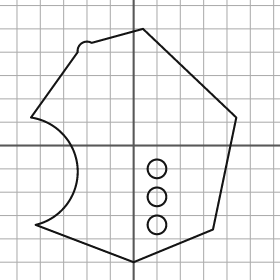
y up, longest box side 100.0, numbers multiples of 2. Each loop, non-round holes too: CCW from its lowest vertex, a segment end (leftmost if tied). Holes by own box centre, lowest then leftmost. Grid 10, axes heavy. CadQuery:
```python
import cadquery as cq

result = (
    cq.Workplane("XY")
    .moveTo(0.0, -50.0)
    .lineTo(34.0, -36.0)
    .lineTo(44.0, 12.0)
    .lineTo(4.0, 50.0)
    .lineTo(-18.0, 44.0)
    .threePointArc((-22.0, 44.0), (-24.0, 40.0))
    .lineTo(-44.0, 12.0)
    .threePointArc((-24.0, -10.0), (-42.0, -34.0))
    .close()
    .moveTo(10.0, -34.0)
    .circle(4.0)
    .moveTo(10.0, -22.0)
    .circle(4.0)
    .moveTo(10.0, -10.0)
    .circle(4.0)
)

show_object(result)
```